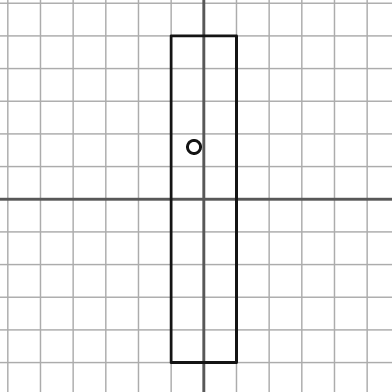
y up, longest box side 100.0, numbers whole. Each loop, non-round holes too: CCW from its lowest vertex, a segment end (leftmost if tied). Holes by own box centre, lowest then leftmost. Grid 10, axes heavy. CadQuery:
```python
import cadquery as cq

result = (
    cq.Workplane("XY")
    .moveTo(-10.0, -50.0)
    .lineTo(10.0, -50.0)
    .lineTo(10.0, 50.0)
    .lineTo(-10.0, 50.0)
    .close()
    .moveTo(-3.0, 16.0)
    .circle(2.0)
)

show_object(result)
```